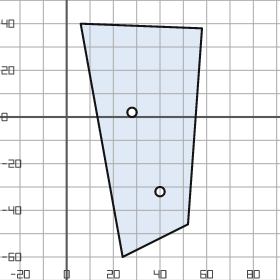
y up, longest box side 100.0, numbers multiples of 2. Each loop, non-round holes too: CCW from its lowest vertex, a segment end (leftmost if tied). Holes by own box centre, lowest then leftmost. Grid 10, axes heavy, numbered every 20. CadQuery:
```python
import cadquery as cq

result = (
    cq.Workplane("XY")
    .moveTo(24.0, -60.0)
    .lineTo(52.0, -46.0)
    .lineTo(58.0, 38.0)
    .lineTo(6.0, 40.0)
    .close()
    .moveTo(40.0, -32.0)
    .circle(2.0)
    .moveTo(28.0, 2.0)
    .circle(2.0)
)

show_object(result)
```